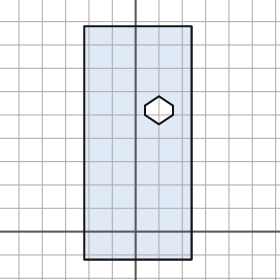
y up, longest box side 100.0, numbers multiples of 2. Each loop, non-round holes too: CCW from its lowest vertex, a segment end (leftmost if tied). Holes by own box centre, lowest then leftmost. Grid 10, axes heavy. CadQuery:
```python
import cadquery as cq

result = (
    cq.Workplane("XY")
    .moveTo(-22.0, -12.0)
    .lineTo(24.0, -12.0)
    .lineTo(24.0, 88.0)
    .lineTo(-22.0, 88.0)
    .close()
    .moveTo(10.0, 46.0)
    .lineTo(16.0, 50.0)
    .lineTo(16.0, 54.0)
    .lineTo(10.0, 58.0)
    .lineTo(4.0, 54.0)
    .lineTo(4.0, 50.0)
    .close()
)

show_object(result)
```